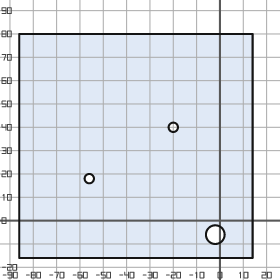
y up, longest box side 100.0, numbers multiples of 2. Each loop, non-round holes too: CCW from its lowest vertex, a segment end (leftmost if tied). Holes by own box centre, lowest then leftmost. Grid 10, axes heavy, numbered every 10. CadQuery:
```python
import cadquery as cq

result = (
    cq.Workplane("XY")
    .moveTo(-86.0, -16.0)
    .lineTo(14.0, -16.0)
    .lineTo(14.0, 80.0)
    .lineTo(-86.0, 80.0)
    .close()
    .moveTo(-2.0, -6.0)
    .circle(4.0)
    .moveTo(-56.0, 18.0)
    .circle(2.0)
    .moveTo(-20.0, 40.0)
    .circle(2.0)
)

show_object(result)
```